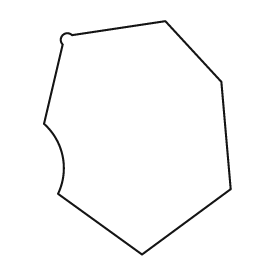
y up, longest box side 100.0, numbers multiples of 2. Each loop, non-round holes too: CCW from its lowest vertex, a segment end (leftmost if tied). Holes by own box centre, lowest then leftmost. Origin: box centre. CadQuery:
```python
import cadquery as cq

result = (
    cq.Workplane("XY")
    .moveTo(2.0, -50.0)
    .lineTo(40.0, -22.0)
    .lineTo(36.0, 24.0)
    .lineTo(12.0, 50.0)
    .lineTo(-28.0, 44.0)
    .threePointArc((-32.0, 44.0), (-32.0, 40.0))
    .lineTo(-40.0, 6.0)
    .threePointArc((-32.0, -8.0), (-34.0, -24.0))
    .close()
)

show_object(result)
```